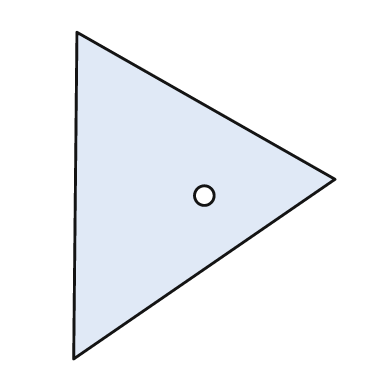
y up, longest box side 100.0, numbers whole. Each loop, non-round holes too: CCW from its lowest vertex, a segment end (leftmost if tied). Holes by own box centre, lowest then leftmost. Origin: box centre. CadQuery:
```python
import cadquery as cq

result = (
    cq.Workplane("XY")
    .moveTo(-40.0, -50.0)
    .lineTo(40.0, 5.0)
    .lineTo(-39.0, 50.0)
    .close()
    .moveTo(0.0, 0.0)
    .circle(3.0)
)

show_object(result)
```